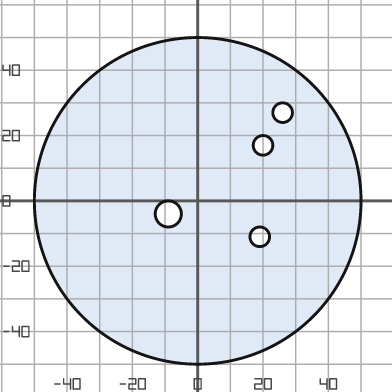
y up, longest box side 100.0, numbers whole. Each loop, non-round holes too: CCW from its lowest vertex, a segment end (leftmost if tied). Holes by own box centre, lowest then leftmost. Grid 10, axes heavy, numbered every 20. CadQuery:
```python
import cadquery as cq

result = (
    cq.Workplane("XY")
    .moveTo(0.0, 0.0)
    .circle(50.0)
    .moveTo(19.0, -11.0)
    .circle(3.0)
    .moveTo(-9.0, -4.0)
    .circle(4.0)
    .moveTo(20.0, 17.0)
    .circle(3.0)
    .moveTo(26.0, 27.0)
    .circle(3.0)
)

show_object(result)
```